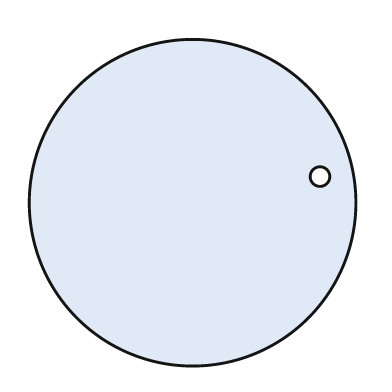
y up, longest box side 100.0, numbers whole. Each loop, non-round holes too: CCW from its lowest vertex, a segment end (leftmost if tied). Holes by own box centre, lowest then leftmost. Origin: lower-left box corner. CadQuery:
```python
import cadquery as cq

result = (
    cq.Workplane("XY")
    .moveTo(50.0, 50.0)
    .circle(50.0)
    .moveTo(89.0, 58.0)
    .circle(3.0)
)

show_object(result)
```